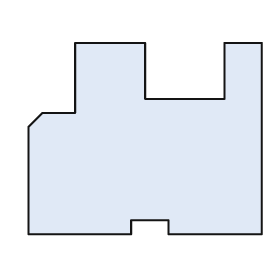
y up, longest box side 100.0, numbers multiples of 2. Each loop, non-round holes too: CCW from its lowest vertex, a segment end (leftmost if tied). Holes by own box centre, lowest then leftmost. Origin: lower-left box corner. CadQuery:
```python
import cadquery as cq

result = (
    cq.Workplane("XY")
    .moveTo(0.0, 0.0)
    .lineTo(44.0, 0.0)
    .lineTo(44.0, 6.0)
    .lineTo(60.0, 6.0)
    .lineTo(60.0, 0.0)
    .lineTo(100.0, 0.0)
    .lineTo(100.0, 82.0)
    .lineTo(84.0, 82.0)
    .lineTo(84.0, 58.0)
    .lineTo(50.0, 58.0)
    .lineTo(50.0, 82.0)
    .lineTo(20.0, 82.0)
    .lineTo(20.0, 52.0)
    .lineTo(6.0, 52.0)
    .lineTo(0.0, 46.0)
    .close()
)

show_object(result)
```